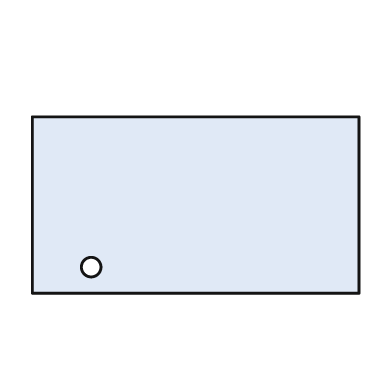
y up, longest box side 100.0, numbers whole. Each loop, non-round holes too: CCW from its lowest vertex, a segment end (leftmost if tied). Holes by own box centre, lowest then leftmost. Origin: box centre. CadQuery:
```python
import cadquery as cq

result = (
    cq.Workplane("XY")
    .moveTo(-50.0, -27.0)
    .lineTo(50.0, -27.0)
    .lineTo(50.0, 27.0)
    .lineTo(-50.0, 27.0)
    .close()
    .moveTo(-32.0, -19.0)
    .circle(3.0)
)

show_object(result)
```